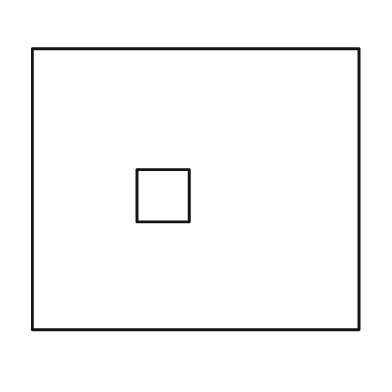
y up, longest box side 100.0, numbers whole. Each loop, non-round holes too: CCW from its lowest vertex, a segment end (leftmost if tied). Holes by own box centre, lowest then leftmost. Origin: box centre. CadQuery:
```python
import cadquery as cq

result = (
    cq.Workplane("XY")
    .moveTo(-50.0, -43.0)
    .lineTo(50.0, -43.0)
    .lineTo(50.0, 43.0)
    .lineTo(-50.0, 43.0)
    .close()
    .moveTo(-18.0, -10.0)
    .lineTo(-2.0, -10.0)
    .lineTo(-2.0, 6.0)
    .lineTo(-18.0, 6.0)
    .close()
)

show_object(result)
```